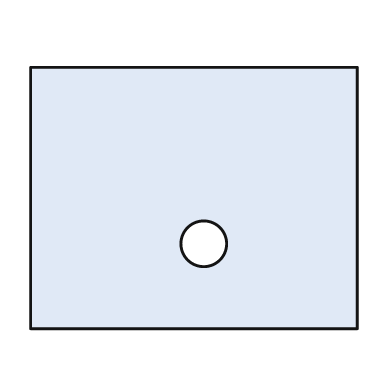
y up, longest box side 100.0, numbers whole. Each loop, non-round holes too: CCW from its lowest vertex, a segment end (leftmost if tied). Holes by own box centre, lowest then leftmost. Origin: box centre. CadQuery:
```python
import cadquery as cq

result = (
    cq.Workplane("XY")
    .moveTo(-50.0, -40.0)
    .lineTo(50.0, -40.0)
    .lineTo(50.0, 40.0)
    .lineTo(-50.0, 40.0)
    .close()
    .moveTo(3.0, -14.0)
    .circle(7.0)
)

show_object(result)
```